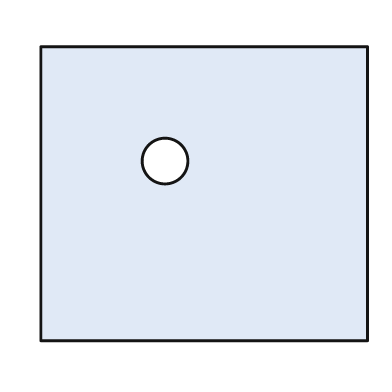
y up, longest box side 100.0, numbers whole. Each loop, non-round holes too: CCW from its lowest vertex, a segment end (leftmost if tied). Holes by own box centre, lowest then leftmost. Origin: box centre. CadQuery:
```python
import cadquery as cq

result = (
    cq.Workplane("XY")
    .moveTo(-50.0, -45.0)
    .lineTo(50.0, -45.0)
    .lineTo(50.0, 45.0)
    .lineTo(-50.0, 45.0)
    .close()
    .moveTo(-12.0, 10.0)
    .circle(7.0)
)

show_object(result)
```